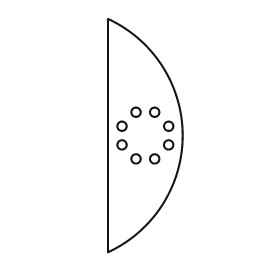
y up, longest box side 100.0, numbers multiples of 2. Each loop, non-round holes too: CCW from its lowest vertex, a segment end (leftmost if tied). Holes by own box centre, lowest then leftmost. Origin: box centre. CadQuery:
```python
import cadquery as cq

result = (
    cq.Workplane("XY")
    .moveTo(-16.0, -50.0)
    .threePointArc((16.0, 0.0), (-16.0, 50.0))
    .close()
    .moveTo(-4.0, -10.0)
    .circle(2.0)
    .moveTo(4.0, -10.0)
    .circle(2.0)
    .moveTo(-10.0, -4.0)
    .circle(2.0)
    .moveTo(10.0, -4.0)
    .circle(2.0)
    .moveTo(-10.0, 4.0)
    .circle(2.0)
    .moveTo(10.0, 4.0)
    .circle(2.0)
    .moveTo(-4.0, 10.0)
    .circle(2.0)
    .moveTo(4.0, 10.0)
    .circle(2.0)
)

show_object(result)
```